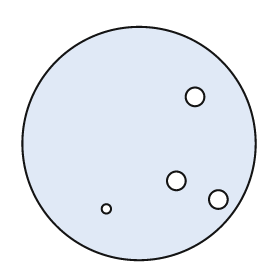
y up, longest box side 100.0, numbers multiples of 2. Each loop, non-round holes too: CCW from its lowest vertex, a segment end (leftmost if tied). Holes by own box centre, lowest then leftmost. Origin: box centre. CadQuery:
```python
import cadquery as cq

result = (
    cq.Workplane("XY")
    .moveTo(0.0, 0.0)
    .circle(50.0)
    .moveTo(-14.0, -28.0)
    .circle(2.0)
    .moveTo(34.0, -24.0)
    .circle(4.0)
    .moveTo(16.0, -16.0)
    .circle(4.0)
    .moveTo(24.0, 20.0)
    .circle(4.0)
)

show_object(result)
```